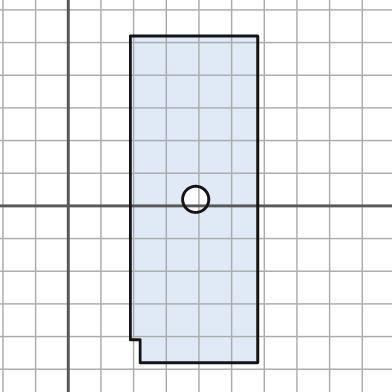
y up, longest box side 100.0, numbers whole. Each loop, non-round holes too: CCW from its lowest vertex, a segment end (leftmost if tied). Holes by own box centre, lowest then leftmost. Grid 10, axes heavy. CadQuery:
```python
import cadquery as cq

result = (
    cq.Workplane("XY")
    .moveTo(22.0, -48.0)
    .lineTo(58.0, -48.0)
    .lineTo(58.0, 52.0)
    .lineTo(19.0, 52.0)
    .lineTo(19.0, -41.0)
    .lineTo(22.0, -41.0)
    .close()
    .moveTo(39.0, 2.0)
    .circle(4.0)
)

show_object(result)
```